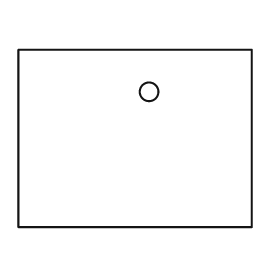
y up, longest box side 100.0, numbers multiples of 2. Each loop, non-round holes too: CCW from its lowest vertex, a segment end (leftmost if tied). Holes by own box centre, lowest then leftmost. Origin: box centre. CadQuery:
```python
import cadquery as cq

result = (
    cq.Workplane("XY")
    .moveTo(-50.0, -38.0)
    .lineTo(50.0, -38.0)
    .lineTo(50.0, 38.0)
    .lineTo(-50.0, 38.0)
    .close()
    .moveTo(6.0, 20.0)
    .circle(4.0)
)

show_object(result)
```